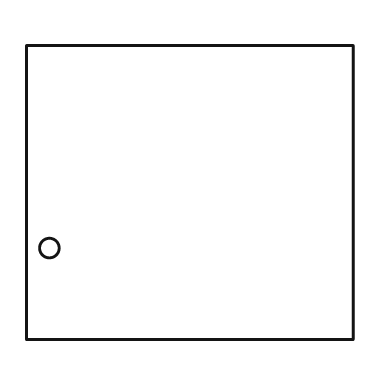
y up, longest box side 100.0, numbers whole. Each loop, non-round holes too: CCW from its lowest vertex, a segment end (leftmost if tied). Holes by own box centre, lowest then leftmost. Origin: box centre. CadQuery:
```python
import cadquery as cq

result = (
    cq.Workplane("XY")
    .moveTo(-50.0, -45.0)
    .lineTo(50.0, -45.0)
    .lineTo(50.0, 45.0)
    .lineTo(-50.0, 45.0)
    .close()
    .moveTo(-43.0, -17.0)
    .circle(3.0)
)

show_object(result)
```